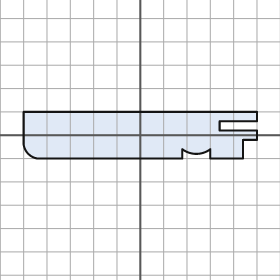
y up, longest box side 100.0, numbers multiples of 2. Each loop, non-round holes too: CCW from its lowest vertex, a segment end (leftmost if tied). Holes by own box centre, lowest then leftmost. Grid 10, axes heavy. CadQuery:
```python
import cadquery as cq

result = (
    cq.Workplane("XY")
    .moveTo(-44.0, -10.0)
    .lineTo(18.0, -10.0)
    .lineTo(18.0, -6.0)
    .threePointArc((24.0, -8.0), (30.0, -6.0))
    .lineTo(30.0, -10.0)
    .lineTo(44.0, -10.0)
    .lineTo(44.0, -2.0)
    .lineTo(50.0, -2.0)
    .lineTo(50.0, 2.0)
    .lineTo(34.0, 2.0)
    .lineTo(34.0, 6.0)
    .lineTo(50.0, 6.0)
    .lineTo(50.0, 10.0)
    .lineTo(-50.0, 10.0)
    .lineTo(-50.0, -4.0)
    .threePointArc((-48.0, -8.0), (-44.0, -10.0))
    .close()
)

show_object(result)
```